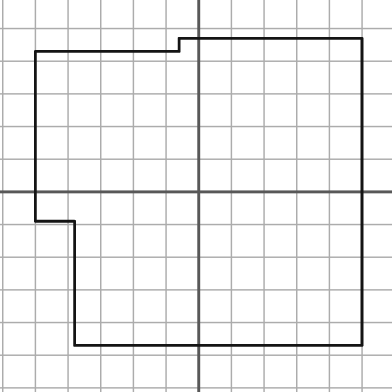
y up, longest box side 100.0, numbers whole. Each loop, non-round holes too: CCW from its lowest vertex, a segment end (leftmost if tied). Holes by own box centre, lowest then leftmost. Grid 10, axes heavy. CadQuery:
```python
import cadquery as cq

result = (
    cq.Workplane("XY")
    .moveTo(-38.0, -47.0)
    .lineTo(50.0, -47.0)
    .lineTo(50.0, 47.0)
    .lineTo(-6.0, 47.0)
    .lineTo(-6.0, 43.0)
    .lineTo(-50.0, 43.0)
    .lineTo(-50.0, -9.0)
    .lineTo(-38.0, -9.0)
    .close()
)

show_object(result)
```